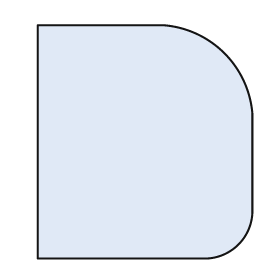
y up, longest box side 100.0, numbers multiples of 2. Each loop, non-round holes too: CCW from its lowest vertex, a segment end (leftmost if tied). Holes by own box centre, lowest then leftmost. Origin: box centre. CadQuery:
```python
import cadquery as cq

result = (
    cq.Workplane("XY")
    .moveTo(-46.0, -50.0)
    .lineTo(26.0, -50.0)
    .threePointArc((40.0, -44.0), (46.0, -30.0))
    .lineTo(46.0, 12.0)
    .threePointArc((34.0, 38.0), (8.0, 50.0))
    .lineTo(-46.0, 50.0)
    .close()
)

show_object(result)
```